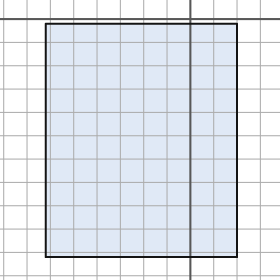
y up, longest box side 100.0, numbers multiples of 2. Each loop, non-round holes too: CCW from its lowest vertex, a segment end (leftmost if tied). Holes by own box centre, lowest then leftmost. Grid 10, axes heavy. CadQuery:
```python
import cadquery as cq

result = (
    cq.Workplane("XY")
    .moveTo(-62.0, -102.0)
    .lineTo(20.0, -102.0)
    .lineTo(20.0, -2.0)
    .lineTo(-62.0, -2.0)
    .close()
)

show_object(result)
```